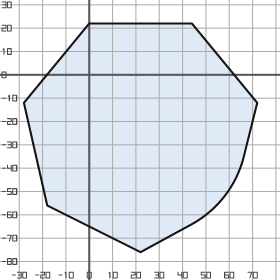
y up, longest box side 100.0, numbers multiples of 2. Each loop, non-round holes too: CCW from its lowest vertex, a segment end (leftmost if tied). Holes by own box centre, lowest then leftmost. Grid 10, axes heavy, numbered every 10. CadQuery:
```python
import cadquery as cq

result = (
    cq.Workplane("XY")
    .moveTo(22.0, -76.0)
    .lineTo(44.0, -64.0)
    .threePointArc((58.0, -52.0), (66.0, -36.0))
    .lineTo(72.0, -12.0)
    .lineTo(44.0, 22.0)
    .lineTo(0.0, 22.0)
    .lineTo(-28.0, -12.0)
    .lineTo(-18.0, -56.0)
    .close()
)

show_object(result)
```